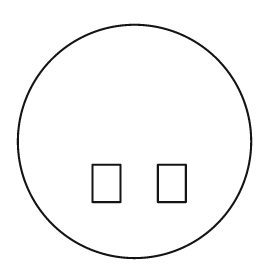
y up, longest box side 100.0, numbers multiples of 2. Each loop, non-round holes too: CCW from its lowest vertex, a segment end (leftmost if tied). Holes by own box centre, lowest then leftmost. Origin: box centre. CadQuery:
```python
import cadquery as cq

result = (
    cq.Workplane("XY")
    .moveTo(0.0, 0.0)
    .circle(50.0)
    .moveTo(-18.0, -26.0)
    .lineTo(-6.0, -26.0)
    .lineTo(-6.0, -10.0)
    .lineTo(-18.0, -10.0)
    .close()
    .moveTo(10.0, -26.0)
    .lineTo(22.0, -26.0)
    .lineTo(22.0, -10.0)
    .lineTo(10.0, -10.0)
    .close()
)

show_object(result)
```